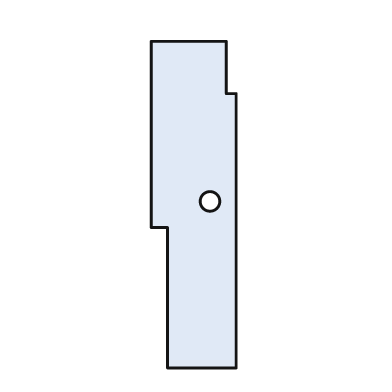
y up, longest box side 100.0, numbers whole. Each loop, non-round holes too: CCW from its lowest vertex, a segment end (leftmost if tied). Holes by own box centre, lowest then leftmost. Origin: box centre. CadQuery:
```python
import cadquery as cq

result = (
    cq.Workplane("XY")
    .moveTo(-8.0, -50.0)
    .lineTo(13.0, -50.0)
    .lineTo(13.0, 34.0)
    .lineTo(10.0, 34.0)
    .lineTo(10.0, 50.0)
    .lineTo(-13.0, 50.0)
    .lineTo(-13.0, -7.0)
    .lineTo(-8.0, -7.0)
    .close()
    .moveTo(5.0, 1.0)
    .circle(3.0)
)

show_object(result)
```